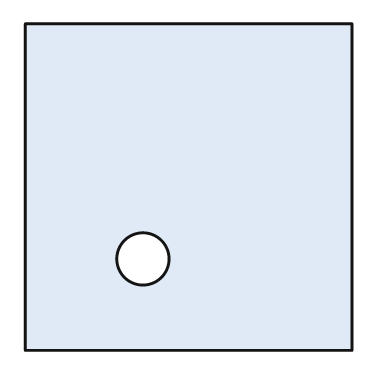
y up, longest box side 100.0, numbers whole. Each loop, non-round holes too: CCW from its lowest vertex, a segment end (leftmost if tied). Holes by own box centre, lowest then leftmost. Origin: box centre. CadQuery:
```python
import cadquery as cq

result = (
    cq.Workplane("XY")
    .moveTo(-50.0, -50.0)
    .lineTo(50.0, -50.0)
    .lineTo(50.0, 50.0)
    .lineTo(-50.0, 50.0)
    .close()
    .moveTo(-14.0, -22.0)
    .circle(8.0)
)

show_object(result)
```